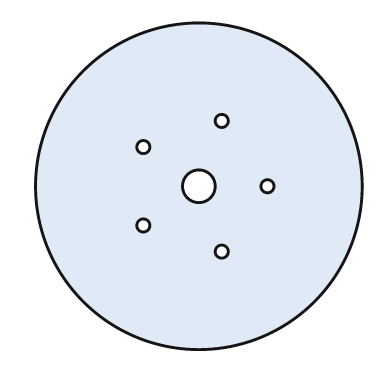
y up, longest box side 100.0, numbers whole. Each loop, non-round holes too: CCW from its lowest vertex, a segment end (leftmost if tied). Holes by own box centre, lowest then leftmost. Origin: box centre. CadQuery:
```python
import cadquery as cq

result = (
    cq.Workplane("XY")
    .moveTo(0.0, 0.0)
    .circle(50.0)
    .moveTo(7.0, -20.0)
    .circle(2.0)
    .moveTo(-17.0, -12.0)
    .circle(2.0)
    .moveTo(0.0, 0.0)
    .circle(5.0)
    .moveTo(21.0, 0.0)
    .circle(2.0)
    .moveTo(-17.0, 12.0)
    .circle(2.0)
    .moveTo(7.0, 20.0)
    .circle(2.0)
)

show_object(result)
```